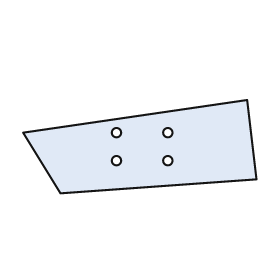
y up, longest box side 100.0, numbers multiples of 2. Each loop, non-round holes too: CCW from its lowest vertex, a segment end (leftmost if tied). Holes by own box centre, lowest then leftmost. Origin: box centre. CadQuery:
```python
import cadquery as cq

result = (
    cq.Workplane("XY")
    .moveTo(-34.0, -20.0)
    .lineTo(50.0, -14.0)
    .lineTo(46.0, 20.0)
    .lineTo(-50.0, 6.0)
    .close()
    .moveTo(-10.0, -6.0)
    .circle(2.0)
    .moveTo(12.0, -6.0)
    .circle(2.0)
    .moveTo(-10.0, 6.0)
    .circle(2.0)
    .moveTo(12.0, 6.0)
    .circle(2.0)
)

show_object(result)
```